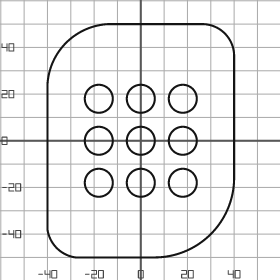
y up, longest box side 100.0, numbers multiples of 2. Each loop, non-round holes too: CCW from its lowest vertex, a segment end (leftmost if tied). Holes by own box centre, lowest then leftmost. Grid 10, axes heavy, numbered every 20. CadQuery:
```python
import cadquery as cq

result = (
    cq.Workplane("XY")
    .moveTo(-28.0, -50.0)
    .lineTo(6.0, -50.0)
    .threePointArc((30.0, -40.0), (40.0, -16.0))
    .lineTo(40.0, 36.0)
    .threePointArc((36.0, 46.0), (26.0, 50.0))
    .lineTo(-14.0, 50.0)
    .threePointArc((-32.0, 42.0), (-40.0, 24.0))
    .lineTo(-40.0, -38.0)
    .threePointArc((-36.0, -46.0), (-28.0, -50.0))
    .close()
    .moveTo(-18.0, -18.0)
    .circle(6.0)
    .moveTo(0.0, -18.0)
    .circle(6.0)
    .moveTo(18.0, -18.0)
    .circle(6.0)
    .moveTo(-18.0, 0.0)
    .circle(6.0)
    .moveTo(0.0, 0.0)
    .circle(6.0)
    .moveTo(18.0, 0.0)
    .circle(6.0)
    .moveTo(-18.0, 18.0)
    .circle(6.0)
    .moveTo(0.0, 18.0)
    .circle(6.0)
    .moveTo(18.0, 18.0)
    .circle(6.0)
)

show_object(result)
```